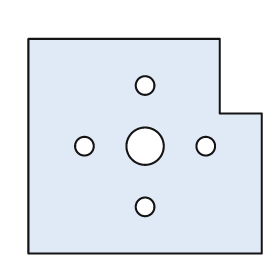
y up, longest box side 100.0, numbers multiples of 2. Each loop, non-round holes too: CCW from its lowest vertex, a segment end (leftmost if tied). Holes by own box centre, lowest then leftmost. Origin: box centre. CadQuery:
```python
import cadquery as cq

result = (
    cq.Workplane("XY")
    .moveTo(-50.0, -46.0)
    .lineTo(50.0, -46.0)
    .lineTo(50.0, 14.0)
    .lineTo(32.0, 14.0)
    .lineTo(32.0, 46.0)
    .lineTo(-50.0, 46.0)
    .close()
    .moveTo(0.0, -26.0)
    .circle(4.0)
    .moveTo(-26.0, 0.0)
    .circle(4.0)
    .moveTo(0.0, 0.0)
    .circle(8.0)
    .moveTo(26.0, 0.0)
    .circle(4.0)
    .moveTo(0.0, 26.0)
    .circle(4.0)
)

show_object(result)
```